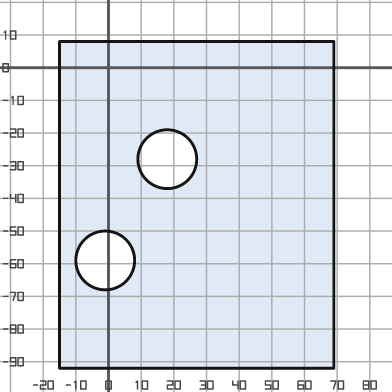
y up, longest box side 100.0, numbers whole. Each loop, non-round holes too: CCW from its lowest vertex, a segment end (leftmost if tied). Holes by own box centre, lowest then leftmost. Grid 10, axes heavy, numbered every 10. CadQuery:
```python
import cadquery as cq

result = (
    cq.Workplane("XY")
    .moveTo(-15.0, -92.0)
    .lineTo(69.0, -92.0)
    .lineTo(69.0, 8.0)
    .lineTo(-15.0, 8.0)
    .close()
    .moveTo(-1.0, -59.0)
    .circle(9.0)
    .moveTo(18.0, -28.0)
    .circle(9.0)
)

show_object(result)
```